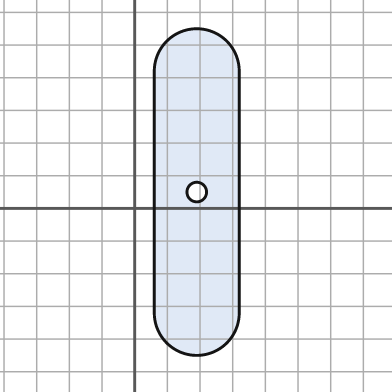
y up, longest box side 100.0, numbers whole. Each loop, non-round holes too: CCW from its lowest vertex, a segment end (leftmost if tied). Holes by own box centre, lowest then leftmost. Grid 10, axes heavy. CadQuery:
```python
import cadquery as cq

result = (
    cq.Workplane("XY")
    .moveTo(6.0, -32.0)
    .threePointArc((19.0, -45.0), (32.0, -32.0))
    .lineTo(32.0, 42.0)
    .threePointArc((19.0, 55.0), (6.0, 42.0))
    .close()
    .moveTo(19.0, 5.0)
    .circle(3.0)
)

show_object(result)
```